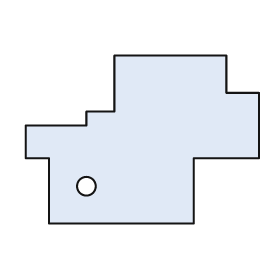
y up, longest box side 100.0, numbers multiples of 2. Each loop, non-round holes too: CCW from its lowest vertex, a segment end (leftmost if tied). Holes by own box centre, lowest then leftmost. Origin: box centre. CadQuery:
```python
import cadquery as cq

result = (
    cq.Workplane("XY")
    .moveTo(-40.0, -36.0)
    .lineTo(22.0, -36.0)
    .lineTo(22.0, -8.0)
    .lineTo(50.0, -8.0)
    .lineTo(50.0, 20.0)
    .lineTo(36.0, 20.0)
    .lineTo(36.0, 36.0)
    .lineTo(-12.0, 36.0)
    .lineTo(-12.0, 12.0)
    .lineTo(-24.0, 12.0)
    .lineTo(-24.0, 6.0)
    .lineTo(-50.0, 6.0)
    .lineTo(-50.0, -8.0)
    .lineTo(-40.0, -8.0)
    .close()
    .moveTo(-24.0, -20.0)
    .circle(4.0)
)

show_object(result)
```